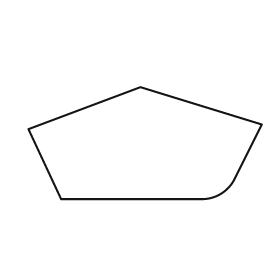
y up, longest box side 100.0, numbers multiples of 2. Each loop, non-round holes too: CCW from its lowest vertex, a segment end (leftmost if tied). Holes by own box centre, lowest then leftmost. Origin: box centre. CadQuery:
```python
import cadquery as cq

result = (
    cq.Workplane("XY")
    .moveTo(-36.0, -24.0)
    .lineTo(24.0, -24.0)
    .threePointArc((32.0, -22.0), (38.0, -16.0))
    .lineTo(50.0, 8.0)
    .lineTo(-2.0, 24.0)
    .lineTo(-50.0, 6.0)
    .close()
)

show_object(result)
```